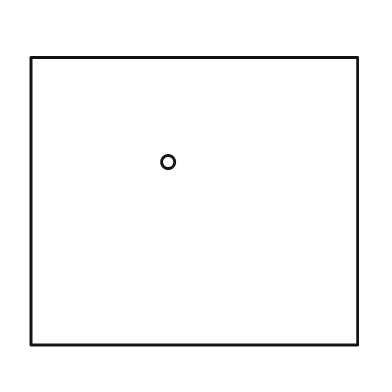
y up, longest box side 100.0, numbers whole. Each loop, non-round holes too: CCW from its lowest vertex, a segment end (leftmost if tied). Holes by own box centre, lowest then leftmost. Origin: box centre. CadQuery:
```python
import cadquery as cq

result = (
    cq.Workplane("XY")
    .moveTo(-50.0, -44.0)
    .lineTo(50.0, -44.0)
    .lineTo(50.0, 44.0)
    .lineTo(-50.0, 44.0)
    .close()
    .moveTo(-8.0, 12.0)
    .circle(2.0)
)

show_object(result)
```